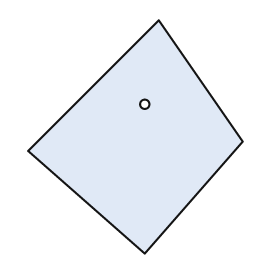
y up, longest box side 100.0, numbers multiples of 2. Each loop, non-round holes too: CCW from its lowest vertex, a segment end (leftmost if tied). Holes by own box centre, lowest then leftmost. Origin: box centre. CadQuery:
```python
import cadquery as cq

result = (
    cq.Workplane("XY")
    .moveTo(4.0, -50.0)
    .lineTo(46.0, -2.0)
    .lineTo(10.0, 50.0)
    .lineTo(-46.0, -6.0)
    .close()
    .moveTo(4.0, 14.0)
    .circle(2.0)
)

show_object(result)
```